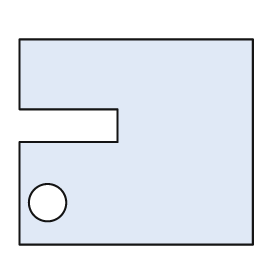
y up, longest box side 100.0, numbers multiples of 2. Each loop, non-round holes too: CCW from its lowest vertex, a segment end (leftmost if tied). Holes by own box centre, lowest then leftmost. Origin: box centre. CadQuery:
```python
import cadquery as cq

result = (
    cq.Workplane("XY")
    .moveTo(-50.0, -44.0)
    .lineTo(50.0, -44.0)
    .lineTo(50.0, 44.0)
    .lineTo(-50.0, 44.0)
    .lineTo(-50.0, 14.0)
    .lineTo(-8.0, 14.0)
    .lineTo(-8.0, 0.0)
    .lineTo(-50.0, 0.0)
    .close()
    .moveTo(-38.0, -26.0)
    .circle(8.0)
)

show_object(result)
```